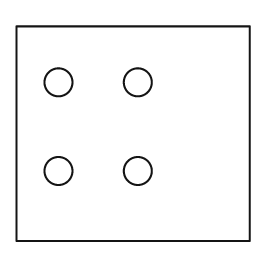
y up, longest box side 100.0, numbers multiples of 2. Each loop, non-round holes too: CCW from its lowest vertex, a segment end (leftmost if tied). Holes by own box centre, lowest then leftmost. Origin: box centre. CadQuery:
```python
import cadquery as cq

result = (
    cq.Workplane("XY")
    .moveTo(-50.0, -46.0)
    .lineTo(50.0, -46.0)
    .lineTo(50.0, 46.0)
    .lineTo(-50.0, 46.0)
    .close()
    .moveTo(-32.0, -16.0)
    .circle(6.0)
    .moveTo(2.0, -16.0)
    .circle(6.0)
    .moveTo(-32.0, 22.0)
    .circle(6.0)
    .moveTo(2.0, 22.0)
    .circle(6.0)
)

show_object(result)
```